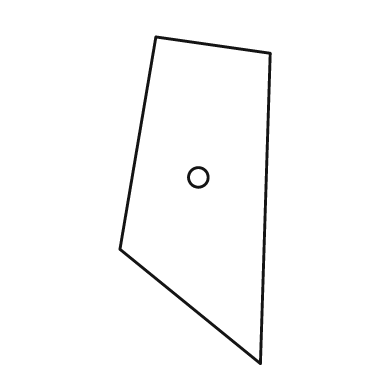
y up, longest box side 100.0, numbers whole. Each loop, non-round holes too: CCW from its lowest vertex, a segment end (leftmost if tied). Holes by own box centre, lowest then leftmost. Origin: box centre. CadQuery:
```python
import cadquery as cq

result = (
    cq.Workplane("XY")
    .moveTo(20.0, -50.0)
    .lineTo(23.0, 45.0)
    .lineTo(-12.0, 50.0)
    .lineTo(-23.0, -15.0)
    .close()
    .moveTo(1.0, 7.0)
    .circle(3.0)
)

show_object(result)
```